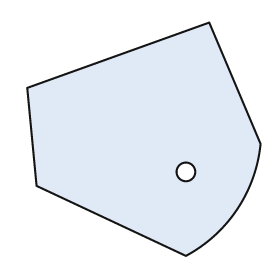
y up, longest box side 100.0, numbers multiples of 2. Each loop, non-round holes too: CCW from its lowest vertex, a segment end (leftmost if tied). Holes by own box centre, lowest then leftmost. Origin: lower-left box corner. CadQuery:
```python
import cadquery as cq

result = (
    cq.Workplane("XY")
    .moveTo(68.0, 0.0)
    .threePointArc((90.0, 20.0), (100.0, 48.0))
    .lineTo(78.0, 100.0)
    .lineTo(0.0, 72.0)
    .lineTo(4.0, 30.0)
    .close()
    .moveTo(68.0, 36.0)
    .circle(4.0)
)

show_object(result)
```